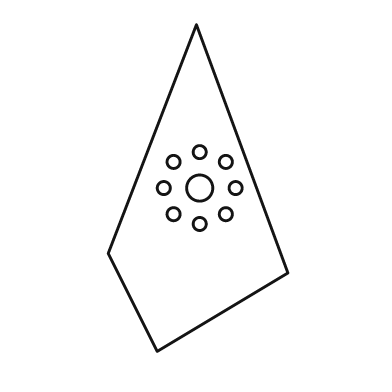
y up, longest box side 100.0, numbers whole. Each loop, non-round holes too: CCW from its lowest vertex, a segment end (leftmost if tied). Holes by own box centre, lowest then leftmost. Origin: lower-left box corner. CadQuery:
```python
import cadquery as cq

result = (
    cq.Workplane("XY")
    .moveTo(15.0, 0.0)
    .lineTo(55.0, 24.0)
    .lineTo(27.0, 100.0)
    .lineTo(0.0, 30.0)
    .close()
    .moveTo(28.0, 39.0)
    .circle(2.0)
    .moveTo(20.0, 42.0)
    .circle(2.0)
    .moveTo(36.0, 42.0)
    .circle(2.0)
    .moveTo(17.0, 50.0)
    .circle(2.0)
    .moveTo(28.0, 50.0)
    .circle(4.0)
    .moveTo(39.0, 50.0)
    .circle(2.0)
    .moveTo(20.0, 58.0)
    .circle(2.0)
    .moveTo(36.0, 58.0)
    .circle(2.0)
    .moveTo(28.0, 61.0)
    .circle(2.0)
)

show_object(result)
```